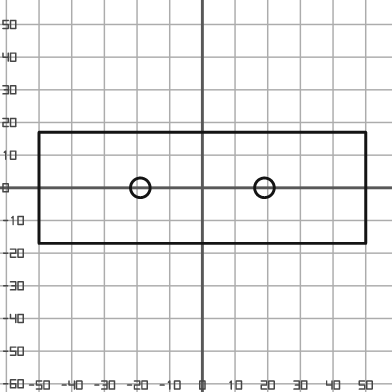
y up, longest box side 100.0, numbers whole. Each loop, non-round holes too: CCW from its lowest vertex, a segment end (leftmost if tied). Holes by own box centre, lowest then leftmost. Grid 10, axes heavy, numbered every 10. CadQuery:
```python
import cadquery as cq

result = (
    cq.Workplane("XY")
    .moveTo(-50.0, -17.0)
    .lineTo(50.0, -17.0)
    .lineTo(50.0, 17.0)
    .lineTo(-50.0, 17.0)
    .close()
    .moveTo(-19.0, 0.0)
    .circle(3.0)
    .moveTo(19.0, 0.0)
    .circle(3.0)
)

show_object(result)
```